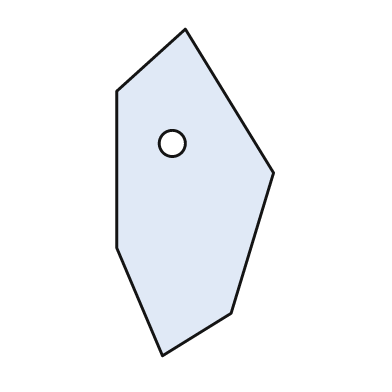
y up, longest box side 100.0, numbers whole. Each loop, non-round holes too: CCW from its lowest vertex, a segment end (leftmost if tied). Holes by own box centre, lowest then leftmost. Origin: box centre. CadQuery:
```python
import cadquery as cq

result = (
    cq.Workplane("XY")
    .moveTo(-10.0, -50.0)
    .lineTo(11.0, -37.0)
    .lineTo(24.0, 6.0)
    .lineTo(-3.0, 50.0)
    .lineTo(-24.0, 31.0)
    .lineTo(-24.0, -17.0)
    .close()
    .moveTo(-7.0, 15.0)
    .circle(4.0)
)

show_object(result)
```